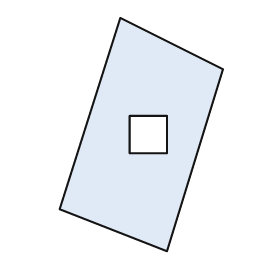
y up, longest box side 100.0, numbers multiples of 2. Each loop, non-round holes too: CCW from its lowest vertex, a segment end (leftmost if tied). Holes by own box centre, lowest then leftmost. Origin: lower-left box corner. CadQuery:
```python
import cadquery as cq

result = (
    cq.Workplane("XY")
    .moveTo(46.0, 0.0)
    .lineTo(70.0, 78.0)
    .lineTo(26.0, 100.0)
    .lineTo(0.0, 18.0)
    .close()
    .moveTo(30.0, 42.0)
    .lineTo(46.0, 42.0)
    .lineTo(46.0, 58.0)
    .lineTo(30.0, 58.0)
    .close()
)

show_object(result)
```